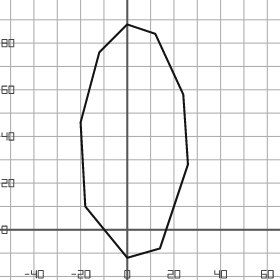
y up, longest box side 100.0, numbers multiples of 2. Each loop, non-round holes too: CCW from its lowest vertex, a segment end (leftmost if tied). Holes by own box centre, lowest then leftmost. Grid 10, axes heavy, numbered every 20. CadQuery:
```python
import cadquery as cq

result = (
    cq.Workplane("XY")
    .moveTo(0.0, -12.0)
    .lineTo(14.0, -8.0)
    .lineTo(26.0, 28.0)
    .lineTo(24.0, 58.0)
    .lineTo(12.0, 84.0)
    .lineTo(0.0, 88.0)
    .lineTo(-12.0, 76.0)
    .lineTo(-20.0, 46.0)
    .lineTo(-18.0, 10.0)
    .close()
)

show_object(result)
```